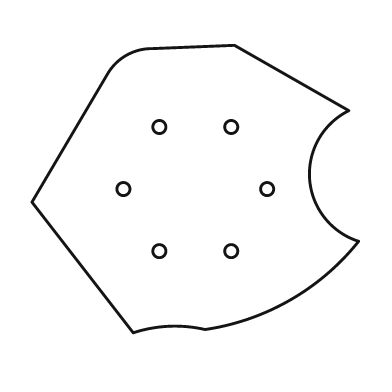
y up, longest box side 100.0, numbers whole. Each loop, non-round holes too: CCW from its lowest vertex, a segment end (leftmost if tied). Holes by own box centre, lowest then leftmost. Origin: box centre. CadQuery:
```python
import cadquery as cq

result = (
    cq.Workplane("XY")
    .moveTo(-19.0, -44.0)
    .threePointArc((-8.0, -42.0), (3.0, -43.0))
    .threePointArc((29.0, -34.0), (50.0, -16.0))
    .threePointArc((35.0, 3.0), (47.0, 24.0))
    .lineTo(12.0, 44.0)
    .lineTo(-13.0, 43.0)
    .threePointArc((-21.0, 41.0), (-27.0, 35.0))
    .lineTo(-50.0, -4.0)
    .close()
    .moveTo(-11.0, -19.0)
    .circle(2.0)
    .moveTo(11.0, -19.0)
    .circle(2.0)
    .moveTo(-22.0, 0.0)
    .circle(2.0)
    .moveTo(22.0, 0.0)
    .circle(2.0)
    .moveTo(-11.0, 19.0)
    .circle(2.0)
    .moveTo(11.0, 19.0)
    .circle(2.0)
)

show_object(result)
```